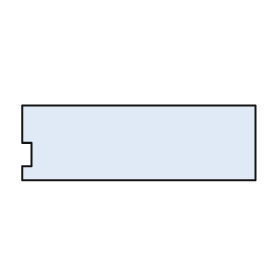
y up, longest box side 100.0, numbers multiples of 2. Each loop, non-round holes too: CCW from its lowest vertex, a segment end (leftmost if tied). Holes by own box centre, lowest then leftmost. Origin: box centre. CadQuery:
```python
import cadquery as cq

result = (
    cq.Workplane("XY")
    .moveTo(-50.0, -16.0)
    .lineTo(50.0, -16.0)
    .lineTo(50.0, 16.0)
    .lineTo(-50.0, 16.0)
    .lineTo(-50.0, 0.0)
    .lineTo(-46.0, 0.0)
    .lineTo(-46.0, -10.0)
    .lineTo(-50.0, -10.0)
    .close()
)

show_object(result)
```